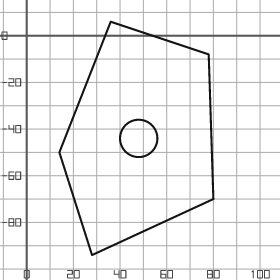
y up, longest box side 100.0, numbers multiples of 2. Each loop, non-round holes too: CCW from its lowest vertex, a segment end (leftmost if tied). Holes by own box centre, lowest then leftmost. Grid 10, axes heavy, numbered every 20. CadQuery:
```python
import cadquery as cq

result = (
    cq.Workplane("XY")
    .moveTo(28.0, -94.0)
    .lineTo(80.0, -70.0)
    .lineTo(78.0, -8.0)
    .lineTo(36.0, 6.0)
    .lineTo(14.0, -50.0)
    .close()
    .moveTo(48.0, -44.0)
    .circle(8.0)
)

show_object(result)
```